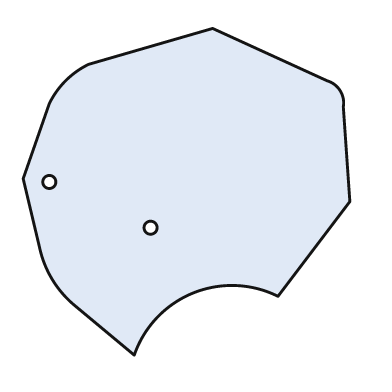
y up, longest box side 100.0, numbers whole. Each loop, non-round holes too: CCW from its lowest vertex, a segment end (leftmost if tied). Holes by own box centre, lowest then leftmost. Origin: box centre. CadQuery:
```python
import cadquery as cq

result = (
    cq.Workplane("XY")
    .moveTo(-16.0, -50.0)
    .threePointArc((2.0, -31.0), (28.0, -32.0))
    .lineTo(50.0, -3.0)
    .lineTo(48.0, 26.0)
    .threePointArc((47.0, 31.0), (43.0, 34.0))
    .lineTo(8.0, 50.0)
    .lineTo(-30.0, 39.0)
    .threePointArc((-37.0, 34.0), (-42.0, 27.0))
    .lineTo(-50.0, 4.0)
    .lineTo(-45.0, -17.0)
    .threePointArc((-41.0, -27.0), (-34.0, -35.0))
    .close()
    .moveTo(-11.0, -11.0)
    .circle(2.0)
    .moveTo(-42.0, 3.0)
    .circle(2.0)
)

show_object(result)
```